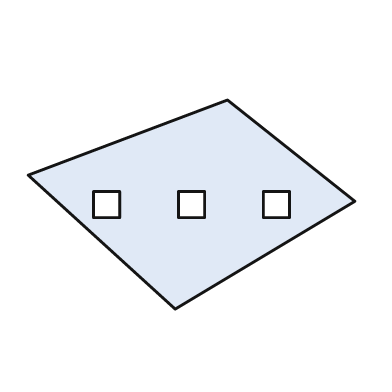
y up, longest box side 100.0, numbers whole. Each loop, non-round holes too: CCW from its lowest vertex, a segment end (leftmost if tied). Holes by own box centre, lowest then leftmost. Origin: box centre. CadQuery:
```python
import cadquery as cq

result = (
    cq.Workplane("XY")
    .moveTo(-5.0, -32.0)
    .lineTo(50.0, 1.0)
    .lineTo(11.0, 32.0)
    .lineTo(-50.0, 9.0)
    .close()
    .moveTo(-30.0, -4.0)
    .lineTo(-22.0, -4.0)
    .lineTo(-22.0, 4.0)
    .lineTo(-30.0, 4.0)
    .close()
    .moveTo(-4.0, -4.0)
    .lineTo(4.0, -4.0)
    .lineTo(4.0, 4.0)
    .lineTo(-4.0, 4.0)
    .close()
    .moveTo(22.0, -4.0)
    .lineTo(30.0, -4.0)
    .lineTo(30.0, 4.0)
    .lineTo(22.0, 4.0)
    .close()
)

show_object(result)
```